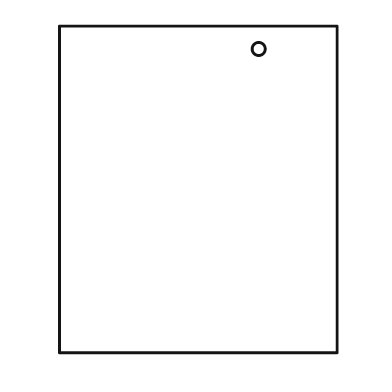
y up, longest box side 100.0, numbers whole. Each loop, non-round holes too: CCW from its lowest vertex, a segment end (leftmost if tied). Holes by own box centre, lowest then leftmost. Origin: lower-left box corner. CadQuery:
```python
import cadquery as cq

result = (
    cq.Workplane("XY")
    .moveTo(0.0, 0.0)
    .lineTo(85.0, 0.0)
    .lineTo(85.0, 100.0)
    .lineTo(0.0, 100.0)
    .close()
    .moveTo(61.0, 93.0)
    .circle(2.0)
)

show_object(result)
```